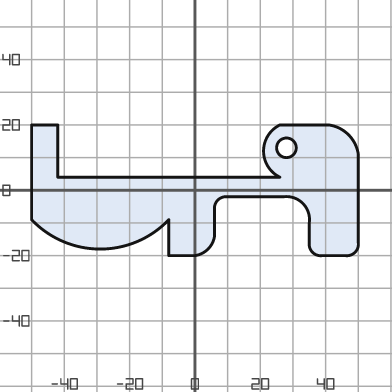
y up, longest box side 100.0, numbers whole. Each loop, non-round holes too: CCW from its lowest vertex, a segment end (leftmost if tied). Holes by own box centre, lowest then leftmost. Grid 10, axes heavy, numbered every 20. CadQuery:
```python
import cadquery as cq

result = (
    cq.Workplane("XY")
    .moveTo(-8.0, -20.0)
    .lineTo(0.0, -20.0)
    .threePointArc((4.0, -18.0), (6.0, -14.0))
    .lineTo(6.0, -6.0)
    .threePointArc((7.0, -3.0), (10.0, -2.0))
    .lineTo(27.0, -2.0)
    .threePointArc((33.0, -4.0), (35.0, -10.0))
    .lineTo(35.0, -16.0)
    .threePointArc((36.0, -19.0), (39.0, -20.0))
    .lineTo(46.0, -20.0)
    .threePointArc((49.0, -19.0), (50.0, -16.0))
    .lineTo(50.0, 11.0)
    .threePointArc((47.0, 17.0), (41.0, 20.0))
    .lineTo(26.0, 20.0)
    .threePointArc((21.0, 12.0), (26.0, 4.0))
    .lineTo(-42.0, 4.0)
    .lineTo(-42.0, 20.0)
    .lineTo(-50.0, 20.0)
    .lineTo(-50.0, -9.0)
    .threePointArc((-29.0, -18.0), (-8.0, -9.0))
    .close()
    .moveTo(28.0, 13.0)
    .circle(3.0)
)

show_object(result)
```